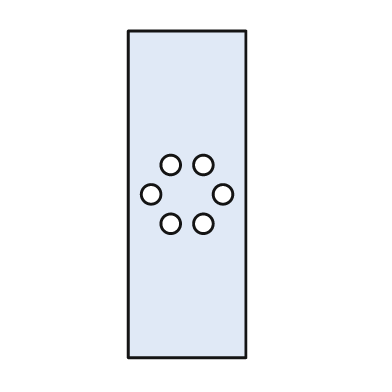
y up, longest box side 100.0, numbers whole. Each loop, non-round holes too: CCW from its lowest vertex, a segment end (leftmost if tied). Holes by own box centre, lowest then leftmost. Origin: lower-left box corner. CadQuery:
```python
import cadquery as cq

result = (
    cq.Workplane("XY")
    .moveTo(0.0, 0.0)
    .lineTo(36.0, 0.0)
    .lineTo(36.0, 100.0)
    .lineTo(0.0, 100.0)
    .close()
    .moveTo(13.0, 41.0)
    .circle(3.0)
    .moveTo(23.0, 41.0)
    .circle(3.0)
    .moveTo(7.0, 50.0)
    .circle(3.0)
    .moveTo(29.0, 50.0)
    .circle(3.0)
    .moveTo(13.0, 59.0)
    .circle(3.0)
    .moveTo(23.0, 59.0)
    .circle(3.0)
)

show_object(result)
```